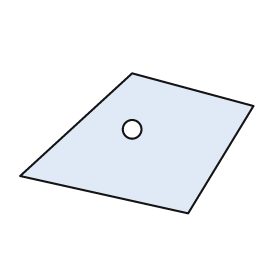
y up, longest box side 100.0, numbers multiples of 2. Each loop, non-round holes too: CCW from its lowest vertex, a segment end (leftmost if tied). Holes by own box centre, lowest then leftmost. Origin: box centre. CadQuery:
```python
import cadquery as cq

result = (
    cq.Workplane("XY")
    .moveTo(22.0, -30.0)
    .lineTo(50.0, 16.0)
    .lineTo(-2.0, 30.0)
    .lineTo(-50.0, -14.0)
    .close()
    .moveTo(-2.0, 6.0)
    .circle(4.0)
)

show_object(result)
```